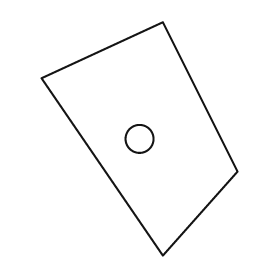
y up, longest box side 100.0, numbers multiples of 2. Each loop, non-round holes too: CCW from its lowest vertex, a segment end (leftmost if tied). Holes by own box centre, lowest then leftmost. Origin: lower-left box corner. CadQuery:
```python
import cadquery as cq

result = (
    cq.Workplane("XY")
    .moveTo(52.0, 0.0)
    .lineTo(84.0, 36.0)
    .lineTo(52.0, 100.0)
    .lineTo(0.0, 76.0)
    .close()
    .moveTo(42.0, 50.0)
    .circle(6.0)
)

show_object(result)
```